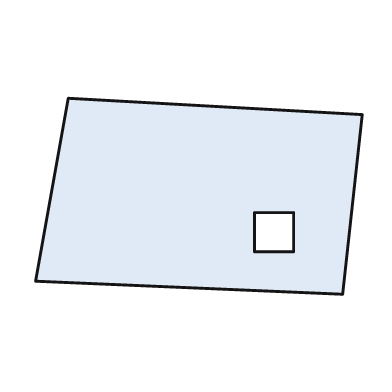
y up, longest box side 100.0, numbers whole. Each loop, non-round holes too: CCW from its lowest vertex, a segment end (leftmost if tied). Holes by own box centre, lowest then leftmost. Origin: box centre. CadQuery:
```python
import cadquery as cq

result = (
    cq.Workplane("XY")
    .moveTo(44.0, -30.0)
    .lineTo(50.0, 25.0)
    .lineTo(-40.0, 30.0)
    .lineTo(-50.0, -26.0)
    .close()
    .moveTo(17.0, -17.0)
    .lineTo(29.0, -17.0)
    .lineTo(29.0, -5.0)
    .lineTo(17.0, -5.0)
    .close()
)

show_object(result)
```